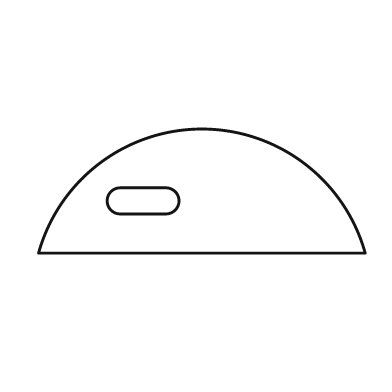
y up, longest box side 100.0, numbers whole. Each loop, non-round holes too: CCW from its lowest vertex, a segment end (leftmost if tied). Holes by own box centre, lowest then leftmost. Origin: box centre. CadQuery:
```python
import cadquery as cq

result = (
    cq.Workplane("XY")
    .moveTo(-50.0, -19.0)
    .lineTo(50.0, -19.0)
    .threePointArc((0.0, 19.0), (-50.0, -19.0))
    .close()
    .moveTo(-25.0, -7.0)
    .lineTo(-11.0, -7.0)
    .threePointArc((-7.0, -3.0), (-11.0, 1.0))
    .lineTo(-25.0, 1.0)
    .threePointArc((-29.0, -3.0), (-25.0, -7.0))
    .close()
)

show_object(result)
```